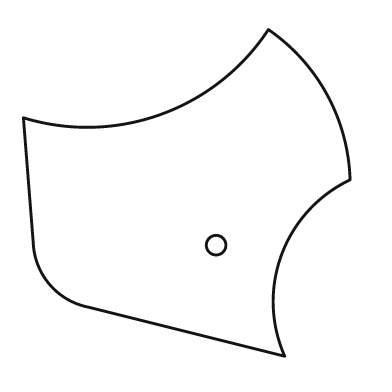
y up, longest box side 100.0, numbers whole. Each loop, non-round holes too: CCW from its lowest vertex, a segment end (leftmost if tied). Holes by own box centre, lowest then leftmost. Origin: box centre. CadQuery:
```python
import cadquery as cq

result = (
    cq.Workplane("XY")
    .moveTo(30.0, -50.0)
    .threePointArc((29.0, -19.0), (50.0, 4.0))
    .threePointArc((43.0, 30.0), (25.0, 50.0))
    .threePointArc((-8.0, 24.0), (-50.0, 23.0))
    .lineTo(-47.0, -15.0)
    .threePointArc((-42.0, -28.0), (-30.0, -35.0))
    .close()
    .moveTo(9.0, -16.0)
    .circle(3.0)
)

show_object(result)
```